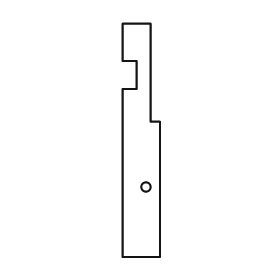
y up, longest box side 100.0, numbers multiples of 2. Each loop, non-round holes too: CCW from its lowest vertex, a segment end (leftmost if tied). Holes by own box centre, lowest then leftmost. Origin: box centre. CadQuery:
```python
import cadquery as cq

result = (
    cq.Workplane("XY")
    .moveTo(-8.0, -50.0)
    .lineTo(8.0, -50.0)
    .lineTo(8.0, 8.0)
    .lineTo(4.0, 8.0)
    .lineTo(4.0, 50.0)
    .lineTo(-8.0, 50.0)
    .lineTo(-8.0, 34.0)
    .lineTo(-2.0, 34.0)
    .lineTo(-2.0, 22.0)
    .lineTo(-8.0, 22.0)
    .close()
    .moveTo(2.0, -20.0)
    .circle(2.0)
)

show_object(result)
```